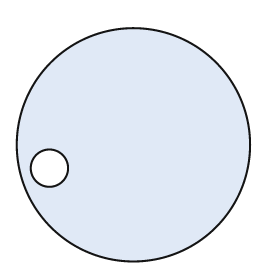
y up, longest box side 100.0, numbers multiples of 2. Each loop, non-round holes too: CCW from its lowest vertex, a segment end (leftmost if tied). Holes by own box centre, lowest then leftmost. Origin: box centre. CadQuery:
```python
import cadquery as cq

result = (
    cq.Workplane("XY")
    .moveTo(0.0, 0.0)
    .circle(50.0)
    .moveTo(-36.0, -10.0)
    .circle(8.0)
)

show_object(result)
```